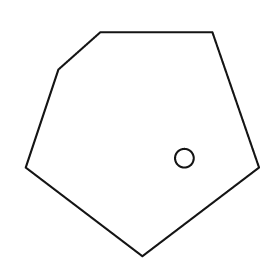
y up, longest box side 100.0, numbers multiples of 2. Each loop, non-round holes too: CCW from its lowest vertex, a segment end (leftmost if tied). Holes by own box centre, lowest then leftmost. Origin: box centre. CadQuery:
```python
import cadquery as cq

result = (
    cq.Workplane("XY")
    .moveTo(0.0, -48.0)
    .lineTo(50.0, -10.0)
    .lineTo(30.0, 48.0)
    .lineTo(-18.0, 48.0)
    .lineTo(-36.0, 32.0)
    .lineTo(-50.0, -10.0)
    .close()
    .moveTo(18.0, -6.0)
    .circle(4.0)
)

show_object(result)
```